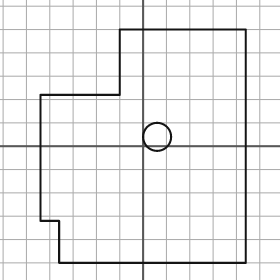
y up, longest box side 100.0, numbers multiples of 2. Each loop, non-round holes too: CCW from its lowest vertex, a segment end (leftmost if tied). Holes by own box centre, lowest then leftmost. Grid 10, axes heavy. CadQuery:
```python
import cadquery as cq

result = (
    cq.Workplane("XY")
    .moveTo(-36.0, -50.0)
    .lineTo(44.0, -50.0)
    .lineTo(44.0, 50.0)
    .lineTo(-10.0, 50.0)
    .lineTo(-10.0, 22.0)
    .lineTo(-44.0, 22.0)
    .lineTo(-44.0, -32.0)
    .lineTo(-36.0, -32.0)
    .close()
    .moveTo(6.0, 4.0)
    .circle(6.0)
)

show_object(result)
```